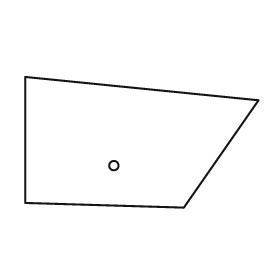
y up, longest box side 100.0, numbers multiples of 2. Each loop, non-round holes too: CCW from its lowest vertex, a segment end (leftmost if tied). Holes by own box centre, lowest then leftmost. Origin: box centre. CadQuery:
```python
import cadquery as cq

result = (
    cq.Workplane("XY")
    .moveTo(18.0, -28.0)
    .lineTo(50.0, 18.0)
    .lineTo(-50.0, 28.0)
    .lineTo(-50.0, -26.0)
    .close()
    .moveTo(-12.0, -10.0)
    .circle(2.0)
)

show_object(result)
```